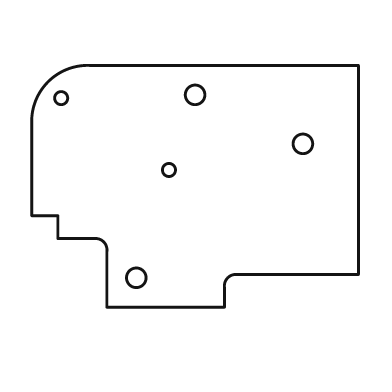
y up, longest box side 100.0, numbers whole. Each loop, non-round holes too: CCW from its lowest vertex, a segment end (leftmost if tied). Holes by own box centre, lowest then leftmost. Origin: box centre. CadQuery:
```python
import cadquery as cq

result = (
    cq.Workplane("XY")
    .moveTo(-27.0, -37.0)
    .lineTo(9.0, -37.0)
    .lineTo(9.0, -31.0)
    .threePointArc((10.0, -28.0), (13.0, -27.0))
    .lineTo(50.0, -27.0)
    .lineTo(50.0, 37.0)
    .lineTo(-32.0, 37.0)
    .threePointArc((-45.0, 32.0), (-50.0, 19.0))
    .lineTo(-50.0, -9.0)
    .lineTo(-42.0, -9.0)
    .lineTo(-42.0, -16.0)
    .lineTo(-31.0, -16.0)
    .threePointArc((-28.0, -17.0), (-27.0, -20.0))
    .close()
    .moveTo(-18.0, -28.0)
    .circle(3.0)
    .moveTo(-8.0, 5.0)
    .circle(2.0)
    .moveTo(33.0, 13.0)
    .circle(3.0)
    .moveTo(-41.0, 27.0)
    .circle(2.0)
    .moveTo(0.0, 28.0)
    .circle(3.0)
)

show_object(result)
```